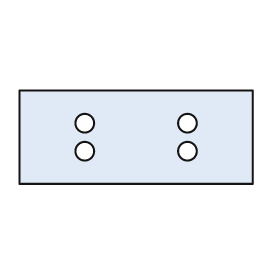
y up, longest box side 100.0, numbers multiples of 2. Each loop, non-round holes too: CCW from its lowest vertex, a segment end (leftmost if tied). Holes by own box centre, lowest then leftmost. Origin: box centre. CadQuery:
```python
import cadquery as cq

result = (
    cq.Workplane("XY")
    .moveTo(-50.0, -20.0)
    .lineTo(50.0, -20.0)
    .lineTo(50.0, 20.0)
    .lineTo(-50.0, 20.0)
    .close()
    .moveTo(-22.0, -6.0)
    .circle(4.0)
    .moveTo(22.0, -6.0)
    .circle(4.0)
    .moveTo(-22.0, 6.0)
    .circle(4.0)
    .moveTo(22.0, 6.0)
    .circle(4.0)
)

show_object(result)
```